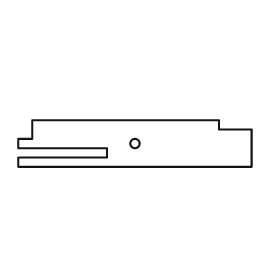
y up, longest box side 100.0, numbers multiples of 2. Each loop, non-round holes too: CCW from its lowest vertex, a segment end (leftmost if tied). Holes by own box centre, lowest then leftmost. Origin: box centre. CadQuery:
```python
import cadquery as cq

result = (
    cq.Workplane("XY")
    .moveTo(-50.0, -10.0)
    .lineTo(50.0, -10.0)
    .lineTo(50.0, 6.0)
    .lineTo(36.0, 6.0)
    .lineTo(36.0, 10.0)
    .lineTo(-44.0, 10.0)
    .lineTo(-44.0, 2.0)
    .lineTo(-50.0, 2.0)
    .lineTo(-50.0, -2.0)
    .lineTo(-12.0, -2.0)
    .lineTo(-12.0, -6.0)
    .lineTo(-50.0, -6.0)
    .close()
    .moveTo(0.0, 0.0)
    .circle(2.0)
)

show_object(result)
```